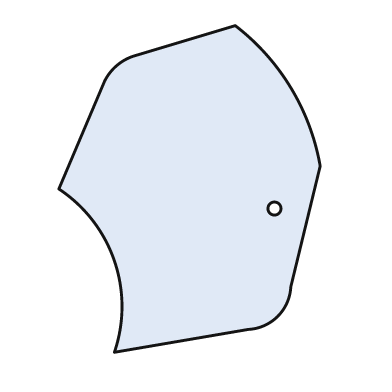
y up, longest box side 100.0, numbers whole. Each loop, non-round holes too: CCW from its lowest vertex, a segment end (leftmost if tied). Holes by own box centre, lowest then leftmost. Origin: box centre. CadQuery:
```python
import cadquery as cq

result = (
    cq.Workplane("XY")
    .moveTo(-23.0, -50.0)
    .lineTo(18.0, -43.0)
    .threePointArc((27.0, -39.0), (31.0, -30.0))
    .lineTo(40.0, 7.0)
    .threePointArc((31.0, 31.0), (14.0, 50.0))
    .lineTo(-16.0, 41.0)
    .threePointArc((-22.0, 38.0), (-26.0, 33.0))
    .lineTo(-40.0, 0.0)
    .threePointArc((-23.0, -22.0), (-23.0, -50.0))
    .close()
    .moveTo(26.0, -6.0)
    .circle(2.0)
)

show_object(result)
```